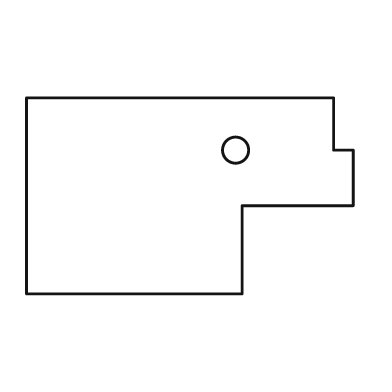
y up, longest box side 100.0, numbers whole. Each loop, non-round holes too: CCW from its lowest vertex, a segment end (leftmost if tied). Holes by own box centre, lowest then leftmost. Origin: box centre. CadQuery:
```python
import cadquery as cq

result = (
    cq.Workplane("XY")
    .moveTo(-50.0, -30.0)
    .lineTo(16.0, -30.0)
    .lineTo(16.0, -3.0)
    .lineTo(50.0, -3.0)
    .lineTo(50.0, 14.0)
    .lineTo(44.0, 14.0)
    .lineTo(44.0, 30.0)
    .lineTo(-50.0, 30.0)
    .close()
    .moveTo(14.0, 14.0)
    .circle(4.0)
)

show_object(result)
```